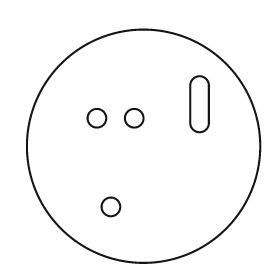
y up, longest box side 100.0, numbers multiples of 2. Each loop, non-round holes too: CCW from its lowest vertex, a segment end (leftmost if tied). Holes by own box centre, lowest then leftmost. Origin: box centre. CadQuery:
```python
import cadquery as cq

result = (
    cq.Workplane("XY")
    .moveTo(0.0, 0.0)
    .circle(50.0)
    .moveTo(-14.0, -26.0)
    .circle(4.0)
    .moveTo(-20.0, 12.0)
    .circle(4.0)
    .moveTo(-4.0, 12.0)
    .circle(4.0)
    .moveTo(20.0, 10.0)
    .threePointArc((24.0, 6.0), (28.0, 10.0))
    .lineTo(28.0, 26.0)
    .threePointArc((24.0, 30.0), (20.0, 26.0))
    .close()
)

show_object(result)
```